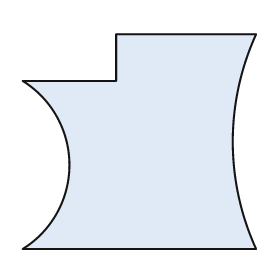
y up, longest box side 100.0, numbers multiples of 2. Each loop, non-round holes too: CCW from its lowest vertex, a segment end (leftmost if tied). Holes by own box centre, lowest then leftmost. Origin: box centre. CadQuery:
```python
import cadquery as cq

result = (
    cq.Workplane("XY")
    .moveTo(-50.0, -46.0)
    .lineTo(50.0, -46.0)
    .threePointArc((40.0, 0.0), (50.0, 46.0))
    .lineTo(-10.0, 46.0)
    .lineTo(-10.0, 26.0)
    .lineTo(-50.0, 26.0)
    .threePointArc((-30.0, -10.0), (-50.0, -46.0))
    .close()
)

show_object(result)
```